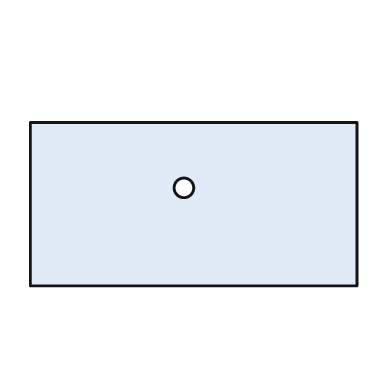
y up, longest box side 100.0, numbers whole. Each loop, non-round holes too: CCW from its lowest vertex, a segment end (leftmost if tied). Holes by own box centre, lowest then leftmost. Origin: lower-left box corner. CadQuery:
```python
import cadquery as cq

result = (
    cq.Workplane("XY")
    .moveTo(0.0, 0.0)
    .lineTo(100.0, 0.0)
    .lineTo(100.0, 50.0)
    .lineTo(0.0, 50.0)
    .close()
    .moveTo(47.0, 30.0)
    .circle(3.0)
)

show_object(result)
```